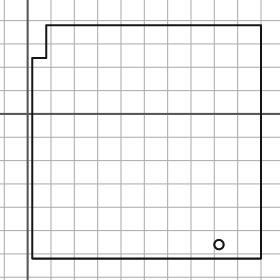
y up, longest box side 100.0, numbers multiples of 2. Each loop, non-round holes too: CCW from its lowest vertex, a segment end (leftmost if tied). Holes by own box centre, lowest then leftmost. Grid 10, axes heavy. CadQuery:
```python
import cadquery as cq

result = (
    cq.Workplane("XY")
    .moveTo(2.0, -62.0)
    .lineTo(100.0, -62.0)
    .lineTo(100.0, 38.0)
    .lineTo(8.0, 38.0)
    .lineTo(8.0, 24.0)
    .lineTo(2.0, 24.0)
    .close()
    .moveTo(82.0, -56.0)
    .circle(2.0)
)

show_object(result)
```